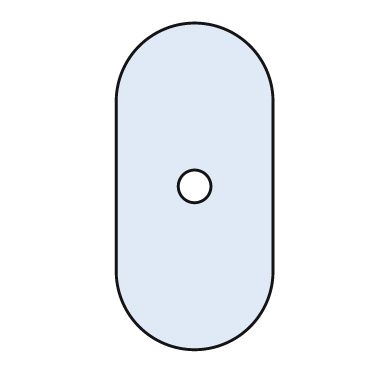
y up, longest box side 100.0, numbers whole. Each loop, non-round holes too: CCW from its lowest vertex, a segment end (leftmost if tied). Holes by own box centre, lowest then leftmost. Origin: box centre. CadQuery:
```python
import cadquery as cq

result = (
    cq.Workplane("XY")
    .moveTo(-24.0, -26.0)
    .threePointArc((0.0, -50.0), (24.0, -26.0))
    .lineTo(24.0, 26.0)
    .threePointArc((0.0, 50.0), (-24.0, 26.0))
    .close()
    .moveTo(0.0, 0.0)
    .circle(5.0)
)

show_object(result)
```